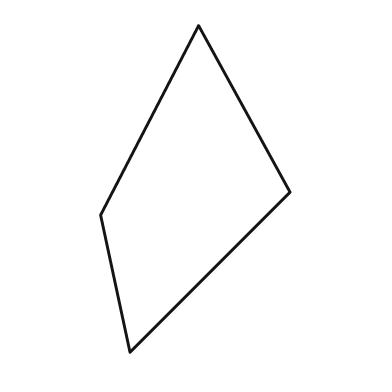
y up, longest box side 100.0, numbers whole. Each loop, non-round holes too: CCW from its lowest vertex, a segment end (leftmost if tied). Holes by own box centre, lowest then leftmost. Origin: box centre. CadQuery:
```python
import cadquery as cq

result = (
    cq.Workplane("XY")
    .moveTo(-20.0, -50.0)
    .lineTo(29.0, -1.0)
    .lineTo(1.0, 50.0)
    .lineTo(-29.0, -8.0)
    .close()
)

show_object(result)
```